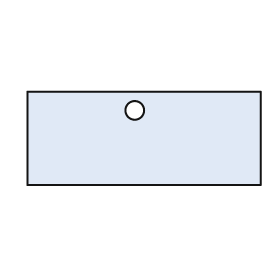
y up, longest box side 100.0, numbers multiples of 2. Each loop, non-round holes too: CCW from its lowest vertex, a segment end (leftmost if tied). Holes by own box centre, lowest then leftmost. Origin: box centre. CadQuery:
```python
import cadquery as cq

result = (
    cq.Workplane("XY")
    .moveTo(-50.0, -20.0)
    .lineTo(50.0, -20.0)
    .lineTo(50.0, 20.0)
    .lineTo(-50.0, 20.0)
    .close()
    .moveTo(-4.0, 12.0)
    .circle(4.0)
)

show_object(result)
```